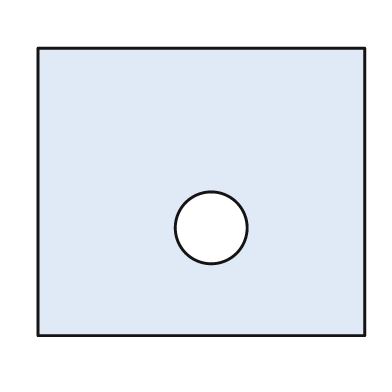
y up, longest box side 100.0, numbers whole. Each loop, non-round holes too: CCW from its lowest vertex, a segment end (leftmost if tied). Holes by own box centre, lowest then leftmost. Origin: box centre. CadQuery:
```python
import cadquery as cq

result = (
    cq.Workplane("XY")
    .moveTo(-50.0, -44.0)
    .lineTo(50.0, -44.0)
    .lineTo(50.0, 44.0)
    .lineTo(-50.0, 44.0)
    .close()
    .moveTo(3.0, -11.0)
    .circle(11.0)
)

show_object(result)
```